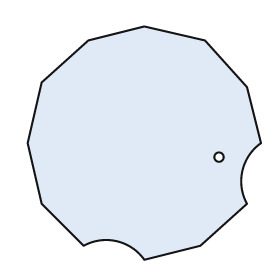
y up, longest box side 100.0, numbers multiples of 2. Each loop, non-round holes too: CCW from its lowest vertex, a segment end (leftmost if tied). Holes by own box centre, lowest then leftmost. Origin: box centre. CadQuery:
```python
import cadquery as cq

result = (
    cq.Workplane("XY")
    .moveTo(0.0, -50.0)
    .lineTo(24.0, -44.0)
    .lineTo(44.0, -26.0)
    .threePointArc((42.0, -12.0), (50.0, 0.0))
    .lineTo(44.0, 24.0)
    .lineTo(26.0, 44.0)
    .lineTo(0.0, 50.0)
    .lineTo(-24.0, 44.0)
    .lineTo(-44.0, 26.0)
    .lineTo(-50.0, 0.0)
    .lineTo(-44.0, -26.0)
    .lineTo(-26.0, -44.0)
    .threePointArc((-12.0, -42.0), (0.0, -50.0))
    .close()
    .moveTo(32.0, -6.0)
    .circle(2.0)
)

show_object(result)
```